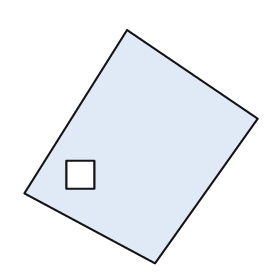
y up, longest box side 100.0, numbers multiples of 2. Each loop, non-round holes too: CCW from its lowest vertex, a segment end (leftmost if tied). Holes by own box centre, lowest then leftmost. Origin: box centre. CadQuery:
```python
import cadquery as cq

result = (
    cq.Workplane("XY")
    .moveTo(6.0, -50.0)
    .lineTo(50.0, 12.0)
    .lineTo(-6.0, 50.0)
    .lineTo(-50.0, -20.0)
    .close()
    .moveTo(-32.0, -18.0)
    .lineTo(-20.0, -18.0)
    .lineTo(-20.0, -6.0)
    .lineTo(-32.0, -6.0)
    .close()
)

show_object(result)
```